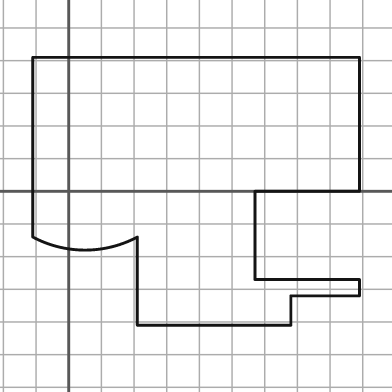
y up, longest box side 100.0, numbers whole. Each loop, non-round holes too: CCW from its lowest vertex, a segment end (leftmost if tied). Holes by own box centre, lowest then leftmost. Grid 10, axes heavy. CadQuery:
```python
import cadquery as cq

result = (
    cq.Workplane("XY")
    .moveTo(21.0, -41.0)
    .lineTo(68.0, -41.0)
    .lineTo(68.0, -32.0)
    .lineTo(89.0, -32.0)
    .lineTo(89.0, -27.0)
    .lineTo(57.0, -27.0)
    .lineTo(57.0, 0.0)
    .lineTo(89.0, 0.0)
    .lineTo(89.0, 41.0)
    .lineTo(-11.0, 41.0)
    .lineTo(-11.0, -14.0)
    .threePointArc((5.0, -18.0), (21.0, -14.0))
    .close()
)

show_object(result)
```